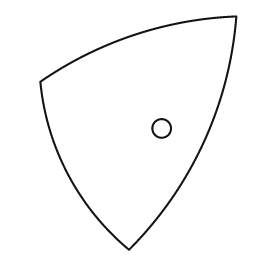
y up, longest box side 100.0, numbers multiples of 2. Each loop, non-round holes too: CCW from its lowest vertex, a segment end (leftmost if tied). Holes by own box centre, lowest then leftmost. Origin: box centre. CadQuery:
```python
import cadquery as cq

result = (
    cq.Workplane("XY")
    .moveTo(-4.0, -50.0)
    .threePointArc((28.0, -4.0), (42.0, 50.0))
    .threePointArc((-2.0, 42.0), (-42.0, 22.0))
    .threePointArc((-30.0, -18.0), (-4.0, -50.0))
    .close()
    .moveTo(10.0, 2.0)
    .circle(4.0)
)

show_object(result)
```